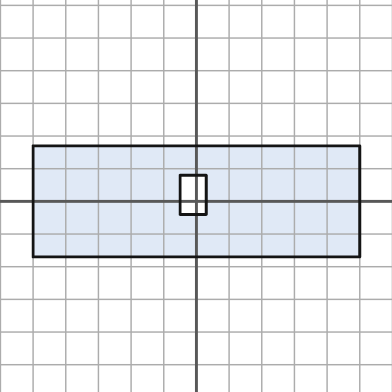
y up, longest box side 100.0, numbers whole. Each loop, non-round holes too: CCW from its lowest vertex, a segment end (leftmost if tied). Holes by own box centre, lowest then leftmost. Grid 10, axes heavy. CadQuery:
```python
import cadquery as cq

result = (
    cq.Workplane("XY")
    .moveTo(-50.0, -17.0)
    .lineTo(50.0, -17.0)
    .lineTo(50.0, 17.0)
    .lineTo(-50.0, 17.0)
    .close()
    .moveTo(-5.0, -4.0)
    .lineTo(3.0, -4.0)
    .lineTo(3.0, 8.0)
    .lineTo(-5.0, 8.0)
    .close()
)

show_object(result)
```